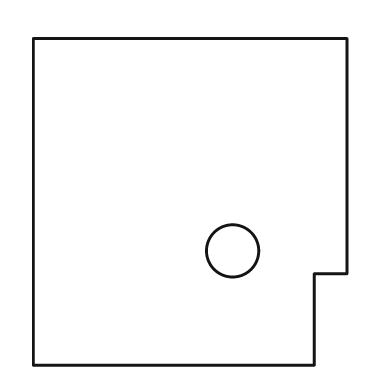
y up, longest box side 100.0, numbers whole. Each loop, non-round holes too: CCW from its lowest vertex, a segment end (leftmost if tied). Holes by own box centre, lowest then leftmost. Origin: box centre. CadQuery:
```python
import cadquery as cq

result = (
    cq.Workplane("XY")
    .moveTo(-48.0, -50.0)
    .lineTo(38.0, -50.0)
    .lineTo(38.0, -22.0)
    .lineTo(48.0, -22.0)
    .lineTo(48.0, 50.0)
    .lineTo(-48.0, 50.0)
    .close()
    .moveTo(13.0, -15.0)
    .circle(8.0)
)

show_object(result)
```